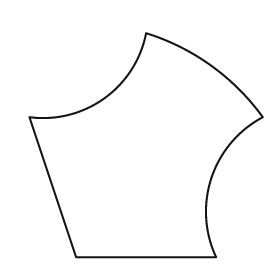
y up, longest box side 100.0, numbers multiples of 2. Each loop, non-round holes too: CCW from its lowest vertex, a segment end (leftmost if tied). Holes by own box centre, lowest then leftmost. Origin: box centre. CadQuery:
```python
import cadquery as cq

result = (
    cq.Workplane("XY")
    .moveTo(-30.0, -48.0)
    .lineTo(30.0, -48.0)
    .threePointArc((28.0, -14.0), (50.0, 12.0))
    .threePointArc((28.0, 34.0), (0.0, 48.0))
    .threePointArc((-18.0, 20.0), (-50.0, 12.0))
    .close()
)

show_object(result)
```